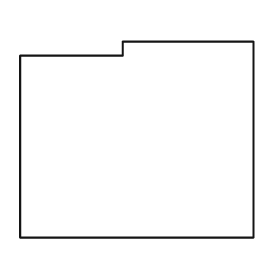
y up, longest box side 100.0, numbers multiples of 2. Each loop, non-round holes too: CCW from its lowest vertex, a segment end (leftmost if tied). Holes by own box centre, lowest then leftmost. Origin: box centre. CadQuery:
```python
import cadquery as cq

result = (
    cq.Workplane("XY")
    .moveTo(-50.0, -42.0)
    .lineTo(50.0, -42.0)
    .lineTo(50.0, 42.0)
    .lineTo(-6.0, 42.0)
    .lineTo(-6.0, 36.0)
    .lineTo(-50.0, 36.0)
    .close()
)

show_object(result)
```